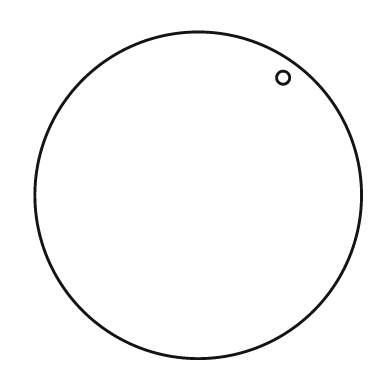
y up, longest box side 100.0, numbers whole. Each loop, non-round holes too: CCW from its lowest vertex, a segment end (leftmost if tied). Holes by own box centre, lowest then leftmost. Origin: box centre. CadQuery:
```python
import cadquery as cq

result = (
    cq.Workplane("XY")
    .moveTo(0.0, 0.0)
    .circle(50.0)
    .moveTo(26.0, 36.0)
    .circle(2.0)
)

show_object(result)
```